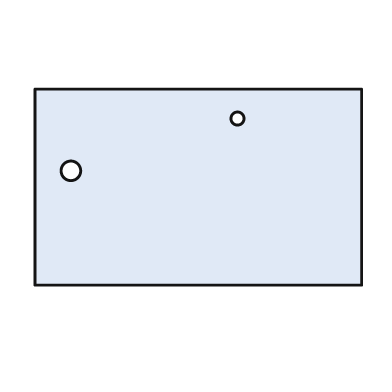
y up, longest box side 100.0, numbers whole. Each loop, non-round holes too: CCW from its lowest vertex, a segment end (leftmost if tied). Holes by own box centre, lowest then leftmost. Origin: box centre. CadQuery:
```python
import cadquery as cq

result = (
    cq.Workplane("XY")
    .moveTo(-50.0, -30.0)
    .lineTo(50.0, -30.0)
    .lineTo(50.0, 30.0)
    .lineTo(-50.0, 30.0)
    .close()
    .moveTo(-39.0, 5.0)
    .circle(3.0)
    .moveTo(12.0, 21.0)
    .circle(2.0)
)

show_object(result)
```